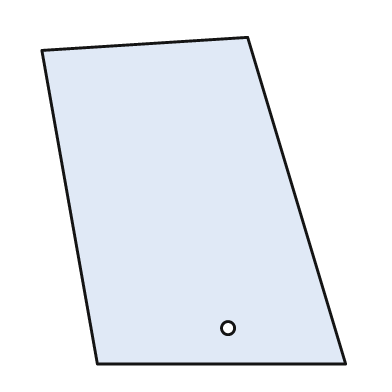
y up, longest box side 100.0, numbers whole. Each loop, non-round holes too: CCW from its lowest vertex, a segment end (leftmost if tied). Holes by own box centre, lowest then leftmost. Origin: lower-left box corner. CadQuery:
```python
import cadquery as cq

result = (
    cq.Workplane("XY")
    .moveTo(17.0, 0.0)
    .lineTo(93.0, 0.0)
    .lineTo(63.0, 100.0)
    .lineTo(0.0, 96.0)
    .close()
    .moveTo(57.0, 11.0)
    .circle(2.0)
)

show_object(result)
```